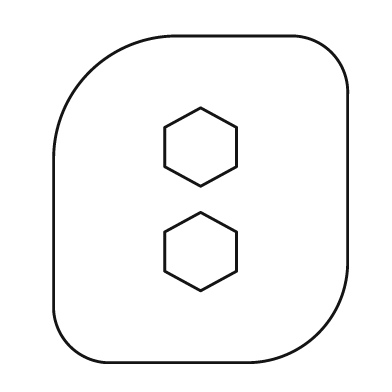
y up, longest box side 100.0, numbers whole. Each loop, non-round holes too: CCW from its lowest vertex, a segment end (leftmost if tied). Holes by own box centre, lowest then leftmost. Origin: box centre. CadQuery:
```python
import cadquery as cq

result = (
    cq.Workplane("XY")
    .moveTo(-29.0, -50.0)
    .lineTo(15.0, -50.0)
    .threePointArc((36.0, -41.0), (45.0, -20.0))
    .lineTo(45.0, 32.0)
    .threePointArc((40.0, 45.0), (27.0, 50.0))
    .lineTo(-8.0, 50.0)
    .threePointArc((-34.0, 39.0), (-45.0, 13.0))
    .lineTo(-45.0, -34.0)
    .threePointArc((-40.0, -45.0), (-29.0, -50.0))
    .close()
    .moveTo(0.0, -28.0)
    .lineTo(11.0, -22.0)
    .lineTo(11.0, -10.0)
    .lineTo(0.0, -4.0)
    .lineTo(-11.0, -10.0)
    .lineTo(-11.0, -22.0)
    .close()
    .moveTo(0.0, 4.0)
    .lineTo(11.0, 10.0)
    .lineTo(11.0, 22.0)
    .lineTo(0.0, 28.0)
    .lineTo(-11.0, 22.0)
    .lineTo(-11.0, 10.0)
    .close()
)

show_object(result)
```